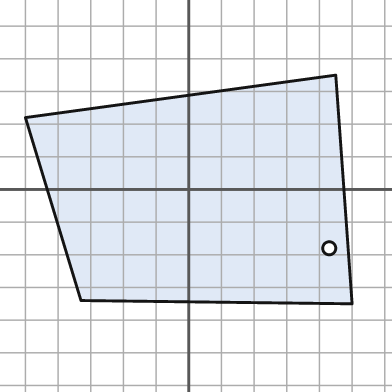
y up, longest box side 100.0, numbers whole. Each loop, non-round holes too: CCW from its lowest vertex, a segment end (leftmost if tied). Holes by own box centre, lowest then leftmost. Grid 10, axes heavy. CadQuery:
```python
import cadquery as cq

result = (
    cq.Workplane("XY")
    .moveTo(50.0, -35.0)
    .lineTo(45.0, 35.0)
    .lineTo(-50.0, 22.0)
    .lineTo(-33.0, -34.0)
    .close()
    .moveTo(43.0, -18.0)
    .circle(2.0)
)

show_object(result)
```